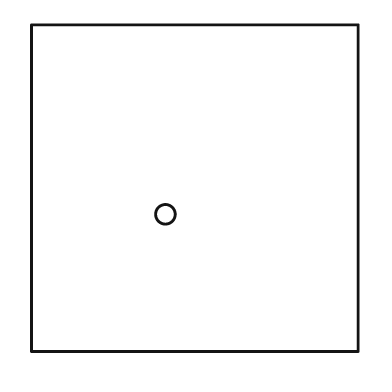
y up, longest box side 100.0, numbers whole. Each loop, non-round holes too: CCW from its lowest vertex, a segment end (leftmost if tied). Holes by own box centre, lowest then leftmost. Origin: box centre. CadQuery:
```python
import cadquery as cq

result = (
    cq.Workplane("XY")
    .moveTo(-50.0, -50.0)
    .lineTo(50.0, -50.0)
    .lineTo(50.0, 50.0)
    .lineTo(-50.0, 50.0)
    .close()
    .moveTo(-9.0, -8.0)
    .circle(3.0)
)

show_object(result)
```